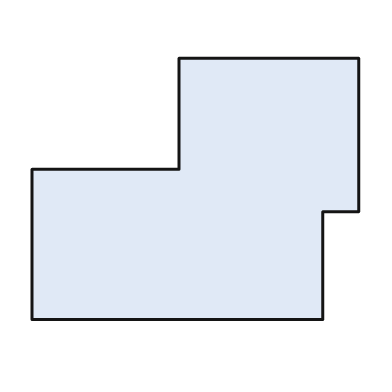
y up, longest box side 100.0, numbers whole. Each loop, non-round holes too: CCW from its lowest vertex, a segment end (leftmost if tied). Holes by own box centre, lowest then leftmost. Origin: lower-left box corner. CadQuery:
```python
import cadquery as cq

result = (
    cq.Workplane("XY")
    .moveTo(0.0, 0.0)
    .lineTo(89.0, 0.0)
    .lineTo(89.0, 33.0)
    .lineTo(100.0, 33.0)
    .lineTo(100.0, 80.0)
    .lineTo(45.0, 80.0)
    .lineTo(45.0, 46.0)
    .lineTo(0.0, 46.0)
    .close()
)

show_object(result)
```